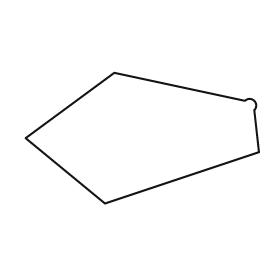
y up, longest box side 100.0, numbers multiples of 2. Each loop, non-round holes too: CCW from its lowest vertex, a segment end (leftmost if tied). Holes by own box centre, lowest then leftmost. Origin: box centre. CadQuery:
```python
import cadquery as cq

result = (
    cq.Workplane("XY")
    .moveTo(-16.0, -28.0)
    .lineTo(50.0, -6.0)
    .lineTo(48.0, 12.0)
    .threePointArc((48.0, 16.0), (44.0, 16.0))
    .lineTo(-12.0, 28.0)
    .lineTo(-50.0, 0.0)
    .close()
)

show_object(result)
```